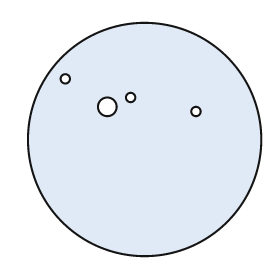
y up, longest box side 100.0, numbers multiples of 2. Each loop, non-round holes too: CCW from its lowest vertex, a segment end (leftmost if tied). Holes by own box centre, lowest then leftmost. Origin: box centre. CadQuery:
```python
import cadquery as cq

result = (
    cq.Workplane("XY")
    .moveTo(0.0, 0.0)
    .circle(50.0)
    .moveTo(22.0, 12.0)
    .circle(2.0)
    .moveTo(-16.0, 14.0)
    .circle(4.0)
    .moveTo(-6.0, 18.0)
    .circle(2.0)
    .moveTo(-34.0, 26.0)
    .circle(2.0)
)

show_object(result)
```